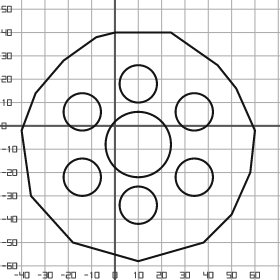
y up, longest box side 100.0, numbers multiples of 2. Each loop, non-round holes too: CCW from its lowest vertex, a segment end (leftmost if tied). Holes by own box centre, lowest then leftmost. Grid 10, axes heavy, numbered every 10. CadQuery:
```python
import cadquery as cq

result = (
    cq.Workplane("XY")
    .moveTo(10.0, -58.0)
    .lineTo(38.0, -50.0)
    .lineTo(50.0, -38.0)
    .lineTo(58.0, -20.0)
    .lineTo(60.0, -2.0)
    .lineTo(52.0, 16.0)
    .lineTo(44.0, 26.0)
    .lineTo(24.0, 40.0)
    .lineTo(0.0, 40.0)
    .lineTo(-8.0, 38.0)
    .lineTo(-22.0, 28.0)
    .lineTo(-34.0, 14.0)
    .lineTo(-40.0, -2.0)
    .lineTo(-36.0, -30.0)
    .lineTo(-18.0, -50.0)
    .close()
    .moveTo(10.0, -34.0)
    .circle(8.0)
    .moveTo(-14.0, -22.0)
    .circle(8.0)
    .moveTo(34.0, -22.0)
    .circle(8.0)
    .moveTo(10.0, -8.0)
    .circle(14.0)
    .moveTo(-14.0, 6.0)
    .circle(8.0)
    .moveTo(34.0, 6.0)
    .circle(8.0)
    .moveTo(10.0, 18.0)
    .circle(8.0)
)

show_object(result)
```